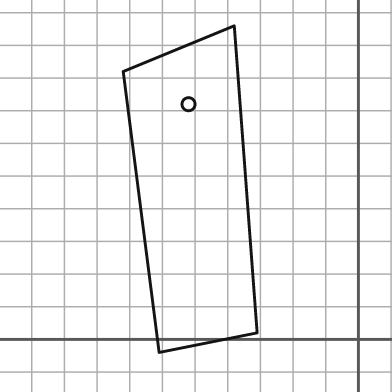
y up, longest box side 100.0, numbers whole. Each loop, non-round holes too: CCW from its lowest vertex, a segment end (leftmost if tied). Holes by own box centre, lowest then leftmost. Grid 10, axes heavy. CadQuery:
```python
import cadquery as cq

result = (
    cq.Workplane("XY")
    .moveTo(-61.0, -4.0)
    .lineTo(-31.0, 2.0)
    .lineTo(-38.0, 96.0)
    .lineTo(-72.0, 82.0)
    .close()
    .moveTo(-52.0, 72.0)
    .circle(2.0)
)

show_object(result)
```